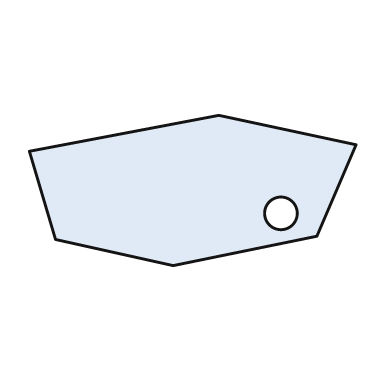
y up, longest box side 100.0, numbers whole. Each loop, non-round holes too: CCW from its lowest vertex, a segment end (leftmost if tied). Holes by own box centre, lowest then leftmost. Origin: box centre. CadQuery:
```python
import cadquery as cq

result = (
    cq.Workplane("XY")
    .moveTo(-6.0, -23.0)
    .lineTo(38.0, -14.0)
    .lineTo(50.0, 14.0)
    .lineTo(8.0, 23.0)
    .lineTo(-50.0, 12.0)
    .lineTo(-42.0, -15.0)
    .close()
    .moveTo(27.0, -7.0)
    .circle(5.0)
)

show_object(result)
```